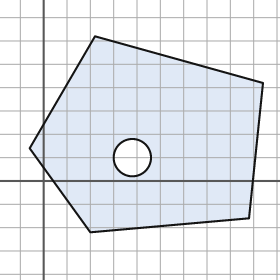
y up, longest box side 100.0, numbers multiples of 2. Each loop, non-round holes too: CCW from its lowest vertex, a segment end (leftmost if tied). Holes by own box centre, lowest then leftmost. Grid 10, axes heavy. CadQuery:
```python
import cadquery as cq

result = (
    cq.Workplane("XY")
    .moveTo(20.0, -22.0)
    .lineTo(88.0, -16.0)
    .lineTo(94.0, 42.0)
    .lineTo(22.0, 62.0)
    .lineTo(-6.0, 14.0)
    .close()
    .moveTo(38.0, 10.0)
    .circle(8.0)
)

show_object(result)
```